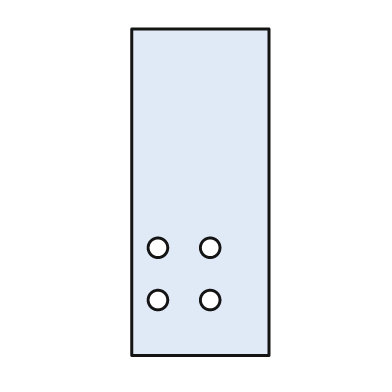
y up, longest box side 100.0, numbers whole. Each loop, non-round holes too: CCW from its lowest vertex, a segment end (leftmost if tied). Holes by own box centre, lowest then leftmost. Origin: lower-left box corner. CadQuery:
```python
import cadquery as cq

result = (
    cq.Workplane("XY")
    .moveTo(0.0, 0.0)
    .lineTo(42.0, 0.0)
    .lineTo(42.0, 100.0)
    .lineTo(0.0, 100.0)
    .close()
    .moveTo(8.0, 17.0)
    .circle(3.0)
    .moveTo(24.0, 17.0)
    .circle(3.0)
    .moveTo(8.0, 33.0)
    .circle(3.0)
    .moveTo(24.0, 33.0)
    .circle(3.0)
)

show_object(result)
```